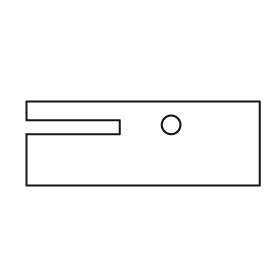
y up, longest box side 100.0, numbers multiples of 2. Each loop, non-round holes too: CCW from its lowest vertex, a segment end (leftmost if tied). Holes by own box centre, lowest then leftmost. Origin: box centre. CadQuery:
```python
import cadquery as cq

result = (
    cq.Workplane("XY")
    .moveTo(-50.0, -18.0)
    .lineTo(50.0, -18.0)
    .lineTo(50.0, 18.0)
    .lineTo(-50.0, 18.0)
    .lineTo(-50.0, 10.0)
    .lineTo(-10.0, 10.0)
    .lineTo(-10.0, 4.0)
    .lineTo(-50.0, 4.0)
    .close()
    .moveTo(12.0, 8.0)
    .circle(4.0)
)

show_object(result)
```